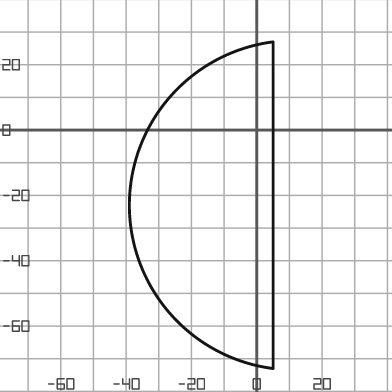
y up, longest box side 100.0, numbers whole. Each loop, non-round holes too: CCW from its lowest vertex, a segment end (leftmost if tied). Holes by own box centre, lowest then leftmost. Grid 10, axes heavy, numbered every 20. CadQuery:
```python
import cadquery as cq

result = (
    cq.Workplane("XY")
    .moveTo(5.0, -73.0)
    .lineTo(5.0, 27.0)
    .threePointArc((-39.0, -23.0), (5.0, -73.0))
    .close()
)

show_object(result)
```